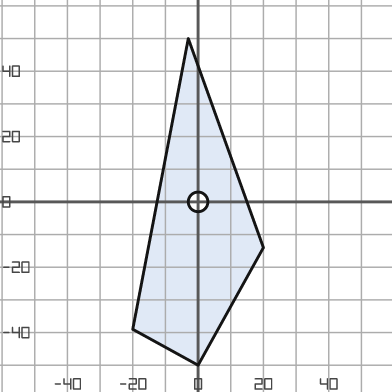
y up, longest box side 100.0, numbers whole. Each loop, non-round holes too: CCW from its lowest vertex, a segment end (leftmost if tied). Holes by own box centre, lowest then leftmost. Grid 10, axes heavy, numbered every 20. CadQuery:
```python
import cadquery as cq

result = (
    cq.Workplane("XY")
    .moveTo(0.0, -50.0)
    .lineTo(20.0, -14.0)
    .lineTo(-3.0, 50.0)
    .lineTo(-20.0, -39.0)
    .close()
    .moveTo(0.0, 0.0)
    .circle(3.0)
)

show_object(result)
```